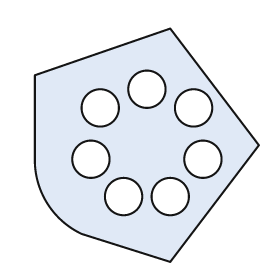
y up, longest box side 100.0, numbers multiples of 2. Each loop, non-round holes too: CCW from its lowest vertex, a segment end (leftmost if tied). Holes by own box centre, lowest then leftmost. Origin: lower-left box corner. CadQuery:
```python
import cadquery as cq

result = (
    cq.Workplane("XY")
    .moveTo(58.0, 0.0)
    .lineTo(96.0, 50.0)
    .lineTo(58.0, 100.0)
    .lineTo(0.0, 80.0)
    .lineTo(0.0, 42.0)
    .threePointArc((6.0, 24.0), (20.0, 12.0))
    .close()
    .moveTo(38.0, 28.0)
    .circle(8.0)
    .moveTo(58.0, 28.0)
    .circle(8.0)
    .moveTo(24.0, 44.0)
    .circle(8.0)
    .moveTo(72.0, 44.0)
    .circle(8.0)
    .moveTo(28.0, 66.0)
    .circle(8.0)
    .moveTo(68.0, 66.0)
    .circle(8.0)
    .moveTo(48.0, 74.0)
    .circle(8.0)
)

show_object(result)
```